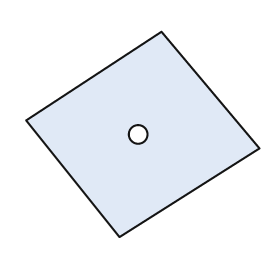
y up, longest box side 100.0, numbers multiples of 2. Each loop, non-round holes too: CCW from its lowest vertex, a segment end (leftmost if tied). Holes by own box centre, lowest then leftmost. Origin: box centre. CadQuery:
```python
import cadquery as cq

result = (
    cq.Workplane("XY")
    .moveTo(-10.0, -44.0)
    .lineTo(50.0, -6.0)
    .lineTo(8.0, 44.0)
    .lineTo(-50.0, 6.0)
    .close()
    .moveTo(-2.0, 0.0)
    .circle(4.0)
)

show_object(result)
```